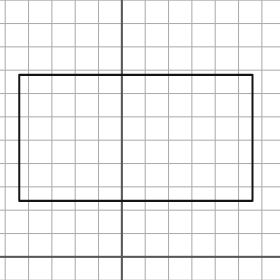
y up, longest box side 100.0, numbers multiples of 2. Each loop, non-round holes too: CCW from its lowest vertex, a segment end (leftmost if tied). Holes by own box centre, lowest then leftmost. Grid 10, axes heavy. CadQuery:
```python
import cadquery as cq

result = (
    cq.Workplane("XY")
    .moveTo(-44.0, 24.0)
    .lineTo(56.0, 24.0)
    .lineTo(56.0, 78.0)
    .lineTo(-44.0, 78.0)
    .close()
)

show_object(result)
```